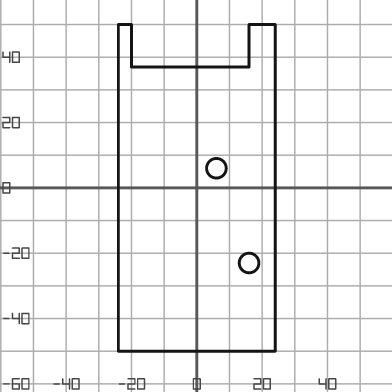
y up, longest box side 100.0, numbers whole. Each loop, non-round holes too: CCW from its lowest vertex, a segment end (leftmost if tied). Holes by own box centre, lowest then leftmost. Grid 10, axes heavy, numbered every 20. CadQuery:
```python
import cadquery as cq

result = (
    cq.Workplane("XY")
    .moveTo(-24.0, -50.0)
    .lineTo(24.0, -50.0)
    .lineTo(24.0, 50.0)
    .lineTo(16.0, 50.0)
    .lineTo(16.0, 37.0)
    .lineTo(-20.0, 37.0)
    .lineTo(-20.0, 50.0)
    .lineTo(-24.0, 50.0)
    .close()
    .moveTo(16.0, -23.0)
    .circle(3.0)
    .moveTo(6.0, 6.0)
    .circle(3.0)
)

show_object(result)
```